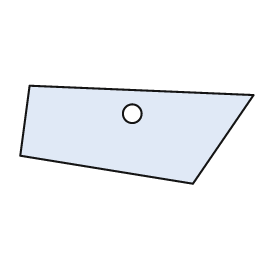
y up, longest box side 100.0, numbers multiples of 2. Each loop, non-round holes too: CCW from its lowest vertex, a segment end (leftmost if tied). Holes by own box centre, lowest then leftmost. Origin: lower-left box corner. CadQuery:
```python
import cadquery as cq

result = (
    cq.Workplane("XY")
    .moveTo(74.0, 0.0)
    .lineTo(100.0, 38.0)
    .lineTo(4.0, 42.0)
    .lineTo(0.0, 12.0)
    .close()
    .moveTo(48.0, 30.0)
    .circle(4.0)
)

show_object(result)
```